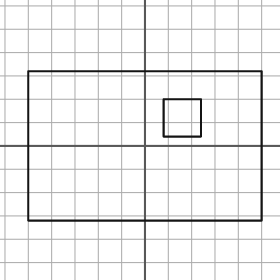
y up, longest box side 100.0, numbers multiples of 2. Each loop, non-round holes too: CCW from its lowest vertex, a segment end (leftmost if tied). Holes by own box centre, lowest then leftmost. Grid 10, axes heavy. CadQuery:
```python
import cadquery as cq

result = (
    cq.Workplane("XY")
    .moveTo(-50.0, -32.0)
    .lineTo(50.0, -32.0)
    .lineTo(50.0, 32.0)
    .lineTo(-50.0, 32.0)
    .close()
    .moveTo(8.0, 4.0)
    .lineTo(24.0, 4.0)
    .lineTo(24.0, 20.0)
    .lineTo(8.0, 20.0)
    .close()
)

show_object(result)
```